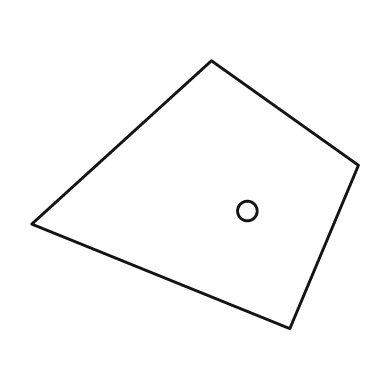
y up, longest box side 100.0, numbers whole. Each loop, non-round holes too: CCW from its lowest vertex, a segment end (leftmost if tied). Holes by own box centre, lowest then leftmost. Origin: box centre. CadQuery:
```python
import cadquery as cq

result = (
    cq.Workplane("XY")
    .moveTo(29.0, -41.0)
    .lineTo(50.0, 9.0)
    .lineTo(5.0, 41.0)
    .lineTo(-50.0, -9.0)
    .close()
    .moveTo(16.0, -5.0)
    .circle(3.0)
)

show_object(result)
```